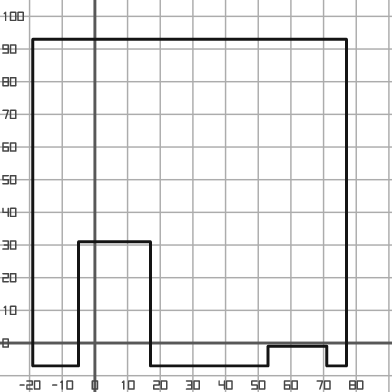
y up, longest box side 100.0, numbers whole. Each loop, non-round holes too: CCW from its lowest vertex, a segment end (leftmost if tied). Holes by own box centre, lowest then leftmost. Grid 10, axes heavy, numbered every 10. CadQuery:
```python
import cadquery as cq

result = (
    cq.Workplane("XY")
    .moveTo(-19.0, -7.0)
    .lineTo(-5.0, -7.0)
    .lineTo(-5.0, 31.0)
    .lineTo(17.0, 31.0)
    .lineTo(17.0, -7.0)
    .lineTo(53.0, -7.0)
    .lineTo(53.0, -1.0)
    .lineTo(71.0, -1.0)
    .lineTo(71.0, -7.0)
    .lineTo(77.0, -7.0)
    .lineTo(77.0, 93.0)
    .lineTo(-19.0, 93.0)
    .close()
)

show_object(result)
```